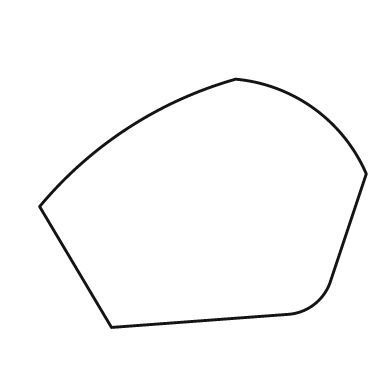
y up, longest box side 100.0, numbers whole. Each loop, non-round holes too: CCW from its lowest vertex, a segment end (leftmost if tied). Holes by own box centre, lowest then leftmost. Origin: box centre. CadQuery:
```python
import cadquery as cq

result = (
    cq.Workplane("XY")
    .moveTo(-28.0, -38.0)
    .lineTo(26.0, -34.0)
    .threePointArc((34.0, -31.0), (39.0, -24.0))
    .lineTo(50.0, 9.0)
    .threePointArc((34.0, 29.0), (10.0, 38.0))
    .threePointArc((-23.0, 23.0), (-50.0, -1.0))
    .close()
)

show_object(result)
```